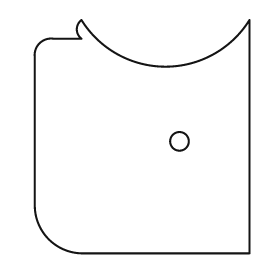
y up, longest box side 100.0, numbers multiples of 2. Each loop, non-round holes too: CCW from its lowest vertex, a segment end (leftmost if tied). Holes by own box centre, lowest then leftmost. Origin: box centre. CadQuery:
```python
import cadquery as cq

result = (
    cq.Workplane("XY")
    .moveTo(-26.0, -50.0)
    .lineTo(46.0, -50.0)
    .lineTo(46.0, 50.0)
    .threePointArc((10.0, 30.0), (-26.0, 50.0))
    .threePointArc((-28.0, 46.0), (-26.0, 42.0))
    .lineTo(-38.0, 42.0)
    .threePointArc((-44.0, 40.0), (-46.0, 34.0))
    .lineTo(-46.0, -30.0)
    .threePointArc((-40.0, -44.0), (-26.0, -50.0))
    .close()
    .moveTo(16.0, -2.0)
    .circle(4.0)
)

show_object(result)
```